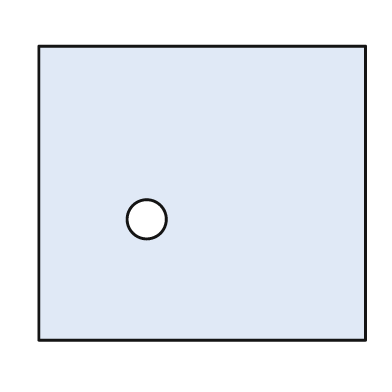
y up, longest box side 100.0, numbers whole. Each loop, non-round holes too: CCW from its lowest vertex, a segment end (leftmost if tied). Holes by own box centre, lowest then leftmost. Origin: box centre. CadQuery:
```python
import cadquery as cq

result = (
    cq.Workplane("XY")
    .moveTo(-50.0, -45.0)
    .lineTo(50.0, -45.0)
    .lineTo(50.0, 45.0)
    .lineTo(-50.0, 45.0)
    .close()
    .moveTo(-17.0, -8.0)
    .circle(6.0)
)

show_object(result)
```